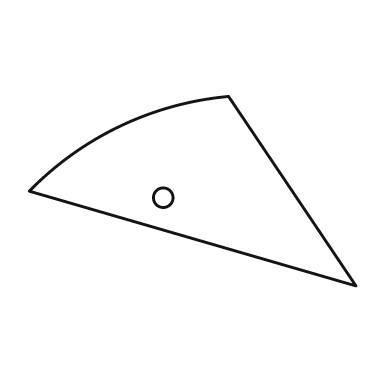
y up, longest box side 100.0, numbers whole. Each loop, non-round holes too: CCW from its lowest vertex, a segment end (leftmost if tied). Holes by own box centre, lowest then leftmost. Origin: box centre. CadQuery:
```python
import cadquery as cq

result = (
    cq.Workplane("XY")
    .moveTo(50.0, -29.0)
    .lineTo(11.0, 29.0)
    .threePointArc((-22.0, 20.0), (-50.0, 0.0))
    .close()
    .moveTo(-9.0, -2.0)
    .circle(3.0)
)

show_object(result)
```